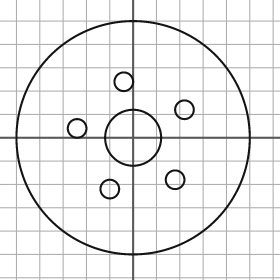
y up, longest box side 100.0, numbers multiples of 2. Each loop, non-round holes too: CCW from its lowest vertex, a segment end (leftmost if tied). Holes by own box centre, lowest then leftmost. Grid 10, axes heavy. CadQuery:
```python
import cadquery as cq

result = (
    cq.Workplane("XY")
    .moveTo(0.0, 0.0)
    .circle(50.0)
    .moveTo(-10.0, -22.0)
    .circle(4.0)
    .moveTo(18.0, -18.0)
    .circle(4.0)
    .moveTo(0.0, 0.0)
    .circle(12.0)
    .moveTo(-24.0, 4.0)
    .circle(4.0)
    .moveTo(22.0, 12.0)
    .circle(4.0)
    .moveTo(-4.0, 24.0)
    .circle(4.0)
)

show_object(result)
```